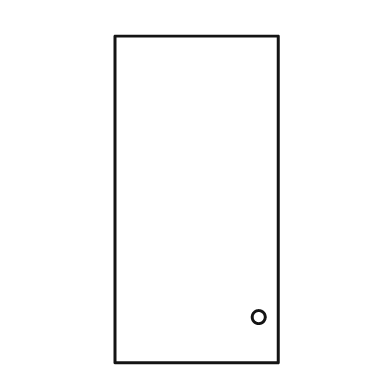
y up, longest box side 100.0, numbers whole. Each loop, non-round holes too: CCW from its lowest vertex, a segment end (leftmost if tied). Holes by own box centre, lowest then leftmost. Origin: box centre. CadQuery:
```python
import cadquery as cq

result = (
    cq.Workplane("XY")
    .moveTo(-25.0, -50.0)
    .lineTo(25.0, -50.0)
    .lineTo(25.0, 50.0)
    .lineTo(-25.0, 50.0)
    .close()
    .moveTo(19.0, -36.0)
    .circle(2.0)
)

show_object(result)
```